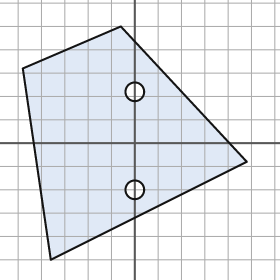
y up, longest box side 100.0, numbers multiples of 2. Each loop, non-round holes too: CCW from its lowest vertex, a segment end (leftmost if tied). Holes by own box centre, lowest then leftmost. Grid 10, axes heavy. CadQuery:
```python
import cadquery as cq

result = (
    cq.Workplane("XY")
    .moveTo(-36.0, -50.0)
    .lineTo(48.0, -8.0)
    .lineTo(-6.0, 50.0)
    .lineTo(-48.0, 32.0)
    .close()
    .moveTo(0.0, -20.0)
    .circle(4.0)
    .moveTo(0.0, 22.0)
    .circle(4.0)
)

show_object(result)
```